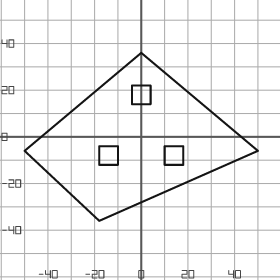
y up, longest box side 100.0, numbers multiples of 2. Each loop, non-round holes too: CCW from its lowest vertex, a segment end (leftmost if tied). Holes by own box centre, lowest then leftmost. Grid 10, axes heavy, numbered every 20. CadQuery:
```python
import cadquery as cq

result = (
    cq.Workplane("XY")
    .moveTo(-18.0, -36.0)
    .lineTo(50.0, -6.0)
    .lineTo(0.0, 36.0)
    .lineTo(-50.0, -6.0)
    .close()
    .moveTo(-18.0, -12.0)
    .lineTo(-10.0, -12.0)
    .lineTo(-10.0, -4.0)
    .lineTo(-18.0, -4.0)
    .close()
    .moveTo(10.0, -12.0)
    .lineTo(18.0, -12.0)
    .lineTo(18.0, -4.0)
    .lineTo(10.0, -4.0)
    .close()
    .moveTo(-4.0, 14.0)
    .lineTo(4.0, 14.0)
    .lineTo(4.0, 22.0)
    .lineTo(-4.0, 22.0)
    .close()
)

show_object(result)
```